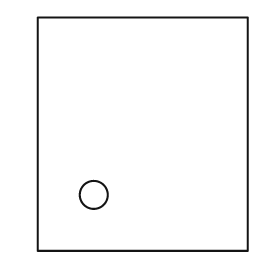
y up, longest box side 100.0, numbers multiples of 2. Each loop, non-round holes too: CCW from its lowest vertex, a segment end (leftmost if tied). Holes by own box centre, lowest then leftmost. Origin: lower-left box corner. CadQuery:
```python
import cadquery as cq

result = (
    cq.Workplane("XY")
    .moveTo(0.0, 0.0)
    .lineTo(90.0, 0.0)
    .lineTo(90.0, 100.0)
    .lineTo(0.0, 100.0)
    .close()
    .moveTo(24.0, 24.0)
    .circle(6.0)
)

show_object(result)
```